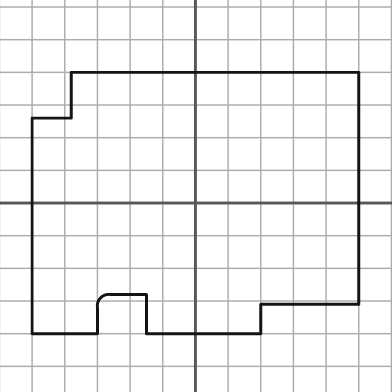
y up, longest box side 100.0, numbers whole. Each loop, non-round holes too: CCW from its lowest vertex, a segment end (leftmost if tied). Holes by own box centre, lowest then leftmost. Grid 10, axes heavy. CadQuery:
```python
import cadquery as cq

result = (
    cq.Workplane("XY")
    .moveTo(-50.0, -40.0)
    .lineTo(-30.0, -40.0)
    .lineTo(-30.0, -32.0)
    .threePointArc((-29.0, -29.0), (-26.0, -28.0))
    .lineTo(-15.0, -28.0)
    .lineTo(-15.0, -40.0)
    .lineTo(20.0, -40.0)
    .lineTo(20.0, -31.0)
    .lineTo(50.0, -31.0)
    .lineTo(50.0, 40.0)
    .lineTo(-38.0, 40.0)
    .lineTo(-38.0, 26.0)
    .lineTo(-50.0, 26.0)
    .close()
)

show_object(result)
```